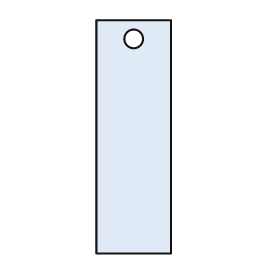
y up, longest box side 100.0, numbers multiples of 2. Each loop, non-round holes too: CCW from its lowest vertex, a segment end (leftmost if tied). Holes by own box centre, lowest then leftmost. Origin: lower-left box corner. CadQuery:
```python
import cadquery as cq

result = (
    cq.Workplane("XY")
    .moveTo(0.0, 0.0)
    .lineTo(32.0, 0.0)
    .lineTo(32.0, 100.0)
    .lineTo(0.0, 100.0)
    .close()
    .moveTo(16.0, 92.0)
    .circle(4.0)
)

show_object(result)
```